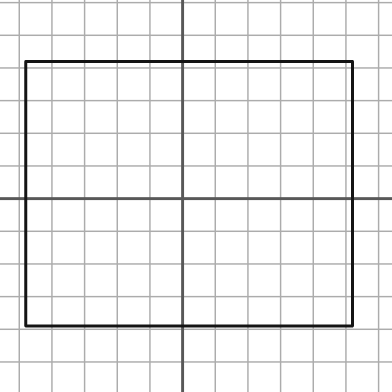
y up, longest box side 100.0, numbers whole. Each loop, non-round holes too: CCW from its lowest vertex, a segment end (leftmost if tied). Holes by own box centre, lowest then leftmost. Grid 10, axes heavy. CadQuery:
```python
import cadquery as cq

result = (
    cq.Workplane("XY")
    .moveTo(-48.0, -39.0)
    .lineTo(52.0, -39.0)
    .lineTo(52.0, 42.0)
    .lineTo(-48.0, 42.0)
    .close()
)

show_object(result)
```